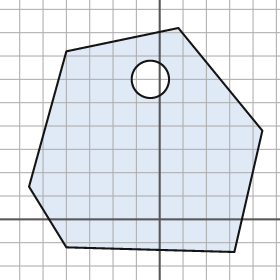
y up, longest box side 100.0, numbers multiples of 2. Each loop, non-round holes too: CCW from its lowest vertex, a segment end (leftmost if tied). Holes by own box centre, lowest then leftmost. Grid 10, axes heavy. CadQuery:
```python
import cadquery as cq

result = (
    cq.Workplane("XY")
    .moveTo(32.0, -14.0)
    .lineTo(44.0, 38.0)
    .lineTo(8.0, 82.0)
    .lineTo(-40.0, 72.0)
    .lineTo(-56.0, 14.0)
    .lineTo(-40.0, -12.0)
    .close()
    .moveTo(-4.0, 60.0)
    .circle(8.0)
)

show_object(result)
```